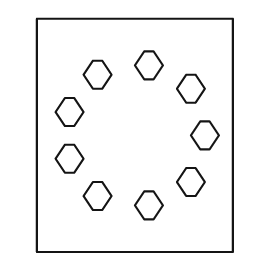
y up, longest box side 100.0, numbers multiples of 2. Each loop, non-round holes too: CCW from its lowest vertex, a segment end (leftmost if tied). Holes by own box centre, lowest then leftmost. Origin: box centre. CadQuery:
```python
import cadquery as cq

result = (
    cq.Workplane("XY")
    .moveTo(-42.0, -50.0)
    .lineTo(42.0, -50.0)
    .lineTo(42.0, 50.0)
    .lineTo(-42.0, 50.0)
    .close()
    .moveTo(4.0, -36.0)
    .lineTo(8.0, -36.0)
    .lineTo(12.0, -30.0)
    .lineTo(8.0, -24.0)
    .lineTo(4.0, -24.0)
    .lineTo(0.0, -30.0)
    .close()
    .moveTo(-18.0, -32.0)
    .lineTo(-14.0, -32.0)
    .lineTo(-10.0, -26.0)
    .lineTo(-14.0, -20.0)
    .lineTo(-18.0, -20.0)
    .lineTo(-22.0, -26.0)
    .close()
    .moveTo(22.0, -26.0)
    .lineTo(26.0, -26.0)
    .lineTo(30.0, -20.0)
    .lineTo(26.0, -14.0)
    .lineTo(22.0, -14.0)
    .lineTo(18.0, -20.0)
    .close()
    .moveTo(-30.0, -16.0)
    .lineTo(-26.0, -16.0)
    .lineTo(-22.0, -10.0)
    .lineTo(-26.0, -4.0)
    .lineTo(-30.0, -4.0)
    .lineTo(-34.0, -10.0)
    .close()
    .moveTo(28.0, -6.0)
    .lineTo(32.0, -6.0)
    .lineTo(36.0, 0.0)
    .lineTo(32.0, 6.0)
    .lineTo(28.0, 6.0)
    .lineTo(24.0, 0.0)
    .close()
    .moveTo(-30.0, 4.0)
    .lineTo(-26.0, 4.0)
    .lineTo(-22.0, 10.0)
    .lineTo(-26.0, 16.0)
    .lineTo(-30.0, 16.0)
    .lineTo(-34.0, 10.0)
    .close()
    .moveTo(22.0, 14.0)
    .lineTo(26.0, 14.0)
    .lineTo(30.0, 20.0)
    .lineTo(26.0, 26.0)
    .lineTo(22.0, 26.0)
    .lineTo(18.0, 20.0)
    .close()
    .moveTo(-18.0, 20.0)
    .lineTo(-14.0, 20.0)
    .lineTo(-10.0, 26.0)
    .lineTo(-14.0, 32.0)
    .lineTo(-18.0, 32.0)
    .lineTo(-22.0, 26.0)
    .close()
    .moveTo(4.0, 24.0)
    .lineTo(8.0, 24.0)
    .lineTo(12.0, 30.0)
    .lineTo(8.0, 36.0)
    .lineTo(4.0, 36.0)
    .lineTo(0.0, 30.0)
    .close()
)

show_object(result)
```